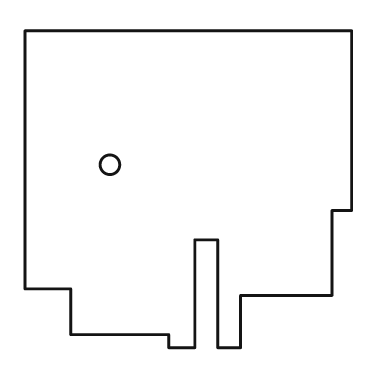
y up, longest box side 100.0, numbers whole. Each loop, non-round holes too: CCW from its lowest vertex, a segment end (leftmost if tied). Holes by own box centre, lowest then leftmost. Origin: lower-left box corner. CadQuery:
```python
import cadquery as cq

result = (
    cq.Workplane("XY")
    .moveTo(44.0, 0.0)
    .lineTo(52.0, 0.0)
    .lineTo(52.0, 33.0)
    .lineTo(59.0, 33.0)
    .lineTo(59.0, 0.0)
    .lineTo(66.0, 0.0)
    .lineTo(66.0, 16.0)
    .lineTo(94.0, 16.0)
    .lineTo(94.0, 42.0)
    .lineTo(100.0, 42.0)
    .lineTo(100.0, 97.0)
    .lineTo(0.0, 97.0)
    .lineTo(0.0, 18.0)
    .lineTo(14.0, 18.0)
    .lineTo(14.0, 4.0)
    .lineTo(44.0, 4.0)
    .close()
    .moveTo(26.0, 56.0)
    .circle(3.0)
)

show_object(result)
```